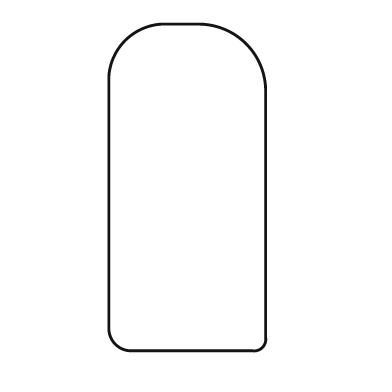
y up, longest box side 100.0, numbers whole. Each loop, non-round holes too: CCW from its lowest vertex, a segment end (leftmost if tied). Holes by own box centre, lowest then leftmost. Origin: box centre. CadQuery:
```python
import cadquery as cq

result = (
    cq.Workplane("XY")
    .moveTo(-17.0, -50.0)
    .lineTo(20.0, -50.0)
    .threePointArc((23.0, -49.0), (24.0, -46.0))
    .lineTo(24.0, 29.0)
    .threePointArc((18.0, 44.0), (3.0, 50.0))
    .lineTo(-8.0, 50.0)
    .threePointArc((-19.0, 45.0), (-24.0, 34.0))
    .lineTo(-24.0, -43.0)
    .threePointArc((-22.0, -48.0), (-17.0, -50.0))
    .close()
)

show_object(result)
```